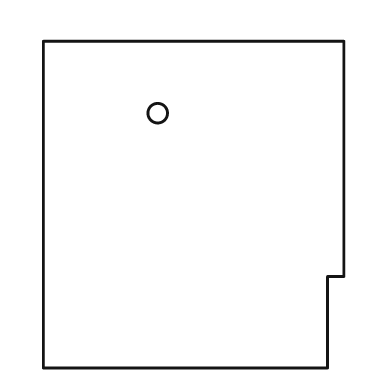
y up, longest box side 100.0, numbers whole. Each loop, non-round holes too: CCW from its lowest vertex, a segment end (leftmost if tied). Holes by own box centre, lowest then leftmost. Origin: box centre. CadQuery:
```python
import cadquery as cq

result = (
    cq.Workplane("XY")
    .moveTo(-46.0, -50.0)
    .lineTo(41.0, -50.0)
    .lineTo(41.0, -22.0)
    .lineTo(46.0, -22.0)
    .lineTo(46.0, 50.0)
    .lineTo(-46.0, 50.0)
    .close()
    .moveTo(-11.0, 28.0)
    .circle(3.0)
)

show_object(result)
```